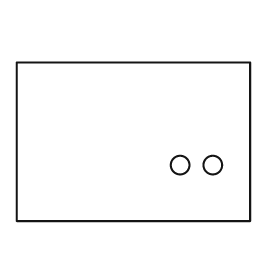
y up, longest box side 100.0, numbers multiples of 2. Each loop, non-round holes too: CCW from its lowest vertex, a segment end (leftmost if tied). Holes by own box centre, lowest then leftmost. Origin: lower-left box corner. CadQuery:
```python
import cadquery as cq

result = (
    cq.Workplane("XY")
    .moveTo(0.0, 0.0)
    .lineTo(100.0, 0.0)
    .lineTo(100.0, 68.0)
    .lineTo(0.0, 68.0)
    .close()
    .moveTo(70.0, 24.0)
    .circle(4.0)
    .moveTo(84.0, 24.0)
    .circle(4.0)
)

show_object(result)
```